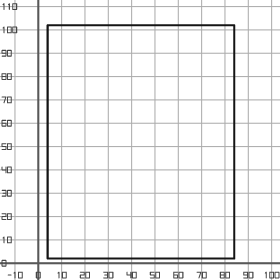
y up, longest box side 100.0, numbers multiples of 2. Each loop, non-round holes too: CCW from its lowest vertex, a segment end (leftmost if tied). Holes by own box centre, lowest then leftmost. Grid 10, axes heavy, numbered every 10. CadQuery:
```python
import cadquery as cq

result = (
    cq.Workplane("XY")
    .moveTo(4.0, 2.0)
    .lineTo(84.0, 2.0)
    .lineTo(84.0, 102.0)
    .lineTo(4.0, 102.0)
    .close()
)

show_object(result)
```